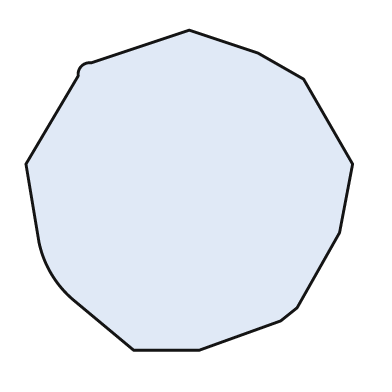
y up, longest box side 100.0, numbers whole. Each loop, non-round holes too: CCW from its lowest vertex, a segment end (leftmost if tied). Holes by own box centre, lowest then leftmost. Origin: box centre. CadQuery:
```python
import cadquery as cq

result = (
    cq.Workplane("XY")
    .moveTo(-17.0, -49.0)
    .lineTo(3.0, -49.0)
    .lineTo(28.0, -40.0)
    .lineTo(33.0, -36.0)
    .lineTo(46.0, -13.0)
    .lineTo(50.0, 8.0)
    .lineTo(35.0, 34.0)
    .lineTo(21.0, 42.0)
    .lineTo(0.0, 49.0)
    .lineTo(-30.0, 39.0)
    .threePointArc((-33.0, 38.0), (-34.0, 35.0))
    .lineTo(-50.0, 8.0)
    .lineTo(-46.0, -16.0)
    .threePointArc((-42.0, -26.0), (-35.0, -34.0))
    .close()
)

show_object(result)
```